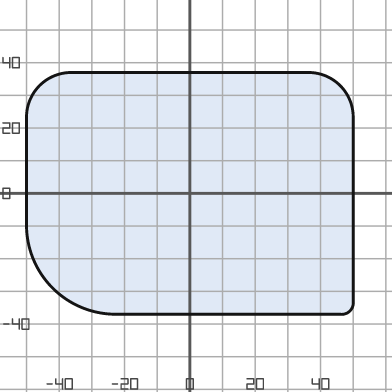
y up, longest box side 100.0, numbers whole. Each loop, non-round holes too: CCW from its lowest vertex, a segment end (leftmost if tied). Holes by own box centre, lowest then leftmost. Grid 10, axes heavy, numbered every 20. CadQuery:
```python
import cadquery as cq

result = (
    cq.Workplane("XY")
    .moveTo(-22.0, -37.0)
    .lineTo(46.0, -37.0)
    .threePointArc((49.0, -36.0), (50.0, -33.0))
    .lineTo(50.0, 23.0)
    .threePointArc((46.0, 33.0), (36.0, 37.0))
    .lineTo(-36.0, 37.0)
    .threePointArc((-46.0, 33.0), (-50.0, 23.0))
    .lineTo(-50.0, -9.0)
    .threePointArc((-42.0, -29.0), (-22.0, -37.0))
    .close()
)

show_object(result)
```